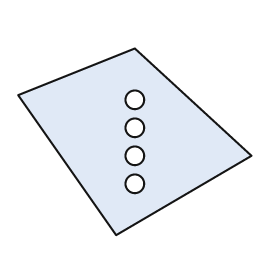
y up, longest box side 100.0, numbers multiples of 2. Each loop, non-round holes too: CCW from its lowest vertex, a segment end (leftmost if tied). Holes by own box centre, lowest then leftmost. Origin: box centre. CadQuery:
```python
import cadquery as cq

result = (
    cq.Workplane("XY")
    .moveTo(-8.0, -40.0)
    .lineTo(50.0, -6.0)
    .lineTo(0.0, 40.0)
    .lineTo(-50.0, 20.0)
    .close()
    .moveTo(0.0, -18.0)
    .circle(4.0)
    .moveTo(0.0, -6.0)
    .circle(4.0)
    .moveTo(0.0, 6.0)
    .circle(4.0)
    .moveTo(0.0, 18.0)
    .circle(4.0)
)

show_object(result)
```